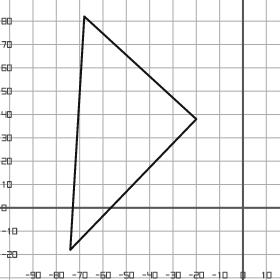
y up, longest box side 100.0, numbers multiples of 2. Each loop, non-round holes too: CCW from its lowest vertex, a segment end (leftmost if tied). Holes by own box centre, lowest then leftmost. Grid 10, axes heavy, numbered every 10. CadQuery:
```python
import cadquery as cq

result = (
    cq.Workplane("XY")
    .moveTo(-74.0, -18.0)
    .lineTo(-20.0, 38.0)
    .lineTo(-68.0, 82.0)
    .close()
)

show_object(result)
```